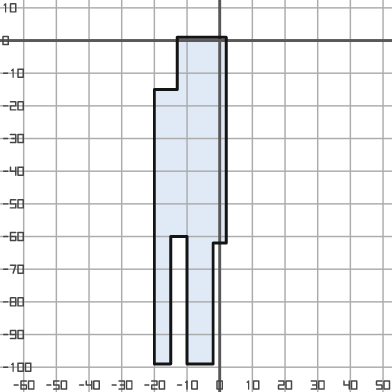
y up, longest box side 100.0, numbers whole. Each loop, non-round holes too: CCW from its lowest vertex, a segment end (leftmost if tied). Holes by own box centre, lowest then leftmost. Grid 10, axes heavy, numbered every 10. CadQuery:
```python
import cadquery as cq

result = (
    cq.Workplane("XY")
    .moveTo(-20.0, -99.0)
    .lineTo(-15.0, -99.0)
    .lineTo(-15.0, -60.0)
    .lineTo(-10.0, -60.0)
    .lineTo(-10.0, -99.0)
    .lineTo(-2.0, -99.0)
    .lineTo(-2.0, -62.0)
    .lineTo(2.0, -62.0)
    .lineTo(2.0, 1.0)
    .lineTo(-13.0, 1.0)
    .lineTo(-13.0, -15.0)
    .lineTo(-20.0, -15.0)
    .close()
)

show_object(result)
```